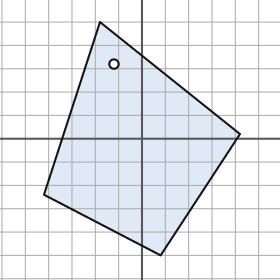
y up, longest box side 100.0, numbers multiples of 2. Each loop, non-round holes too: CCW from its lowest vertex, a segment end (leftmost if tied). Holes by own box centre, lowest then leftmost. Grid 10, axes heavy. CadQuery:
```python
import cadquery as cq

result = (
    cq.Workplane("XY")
    .moveTo(8.0, -50.0)
    .lineTo(42.0, 2.0)
    .lineTo(-18.0, 50.0)
    .lineTo(-42.0, -24.0)
    .close()
    .moveTo(-12.0, 32.0)
    .circle(2.0)
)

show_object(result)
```